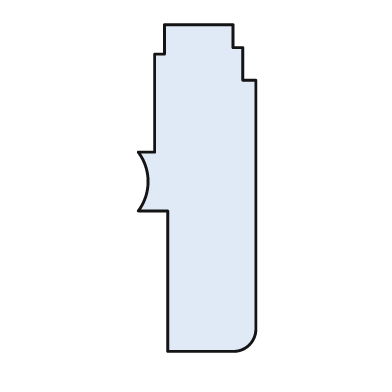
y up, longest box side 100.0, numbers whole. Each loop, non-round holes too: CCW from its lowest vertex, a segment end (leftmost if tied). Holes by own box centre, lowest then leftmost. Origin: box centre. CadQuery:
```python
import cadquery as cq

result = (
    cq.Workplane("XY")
    .moveTo(-9.0, -50.0)
    .lineTo(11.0, -50.0)
    .threePointArc((16.0, -48.0), (18.0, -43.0))
    .lineTo(18.0, 33.0)
    .lineTo(14.0, 33.0)
    .lineTo(14.0, 43.0)
    .lineTo(11.0, 43.0)
    .lineTo(11.0, 50.0)
    .lineTo(-10.0, 50.0)
    .lineTo(-10.0, 41.0)
    .lineTo(-13.0, 41.0)
    .lineTo(-13.0, 11.0)
    .lineTo(-18.0, 11.0)
    .threePointArc((-15.0, 2.0), (-18.0, -7.0))
    .lineTo(-9.0, -7.0)
    .close()
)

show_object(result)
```